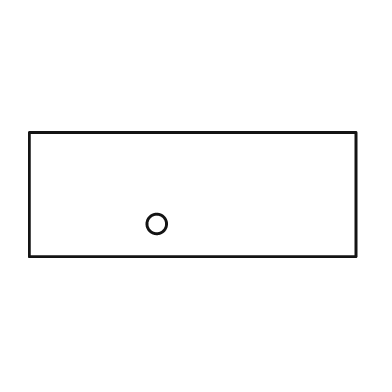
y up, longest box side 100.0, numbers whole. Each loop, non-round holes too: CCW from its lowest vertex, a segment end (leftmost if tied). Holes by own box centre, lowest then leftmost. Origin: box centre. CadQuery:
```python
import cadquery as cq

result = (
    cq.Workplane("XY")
    .moveTo(-50.0, -19.0)
    .lineTo(50.0, -19.0)
    .lineTo(50.0, 19.0)
    .lineTo(-50.0, 19.0)
    .close()
    .moveTo(-11.0, -9.0)
    .circle(3.0)
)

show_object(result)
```